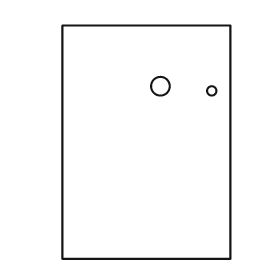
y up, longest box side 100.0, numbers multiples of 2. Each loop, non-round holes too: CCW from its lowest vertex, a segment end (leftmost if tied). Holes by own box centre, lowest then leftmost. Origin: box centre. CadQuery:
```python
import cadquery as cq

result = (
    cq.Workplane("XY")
    .moveTo(-36.0, -50.0)
    .lineTo(36.0, -50.0)
    .lineTo(36.0, 50.0)
    .lineTo(-36.0, 50.0)
    .close()
    .moveTo(28.0, 22.0)
    .circle(2.0)
    .moveTo(6.0, 24.0)
    .circle(4.0)
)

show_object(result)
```